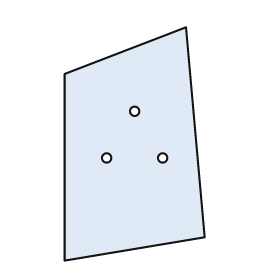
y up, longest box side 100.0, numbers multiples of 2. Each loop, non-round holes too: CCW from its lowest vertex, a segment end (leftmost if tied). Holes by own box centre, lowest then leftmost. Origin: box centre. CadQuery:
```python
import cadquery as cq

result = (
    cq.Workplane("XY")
    .moveTo(-30.0, -50.0)
    .lineTo(30.0, -40.0)
    .lineTo(22.0, 50.0)
    .lineTo(-30.0, 30.0)
    .close()
    .moveTo(-12.0, -6.0)
    .circle(2.0)
    .moveTo(12.0, -6.0)
    .circle(2.0)
    .moveTo(0.0, 14.0)
    .circle(2.0)
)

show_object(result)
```